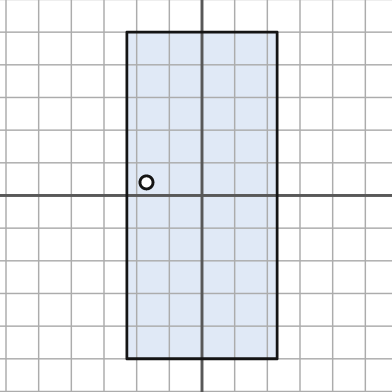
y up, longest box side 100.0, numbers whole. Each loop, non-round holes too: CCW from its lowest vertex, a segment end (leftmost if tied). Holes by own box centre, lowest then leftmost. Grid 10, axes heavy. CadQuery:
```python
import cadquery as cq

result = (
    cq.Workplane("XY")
    .moveTo(-23.0, -50.0)
    .lineTo(23.0, -50.0)
    .lineTo(23.0, 50.0)
    .lineTo(-23.0, 50.0)
    .close()
    .moveTo(-17.0, 4.0)
    .circle(2.0)
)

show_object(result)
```